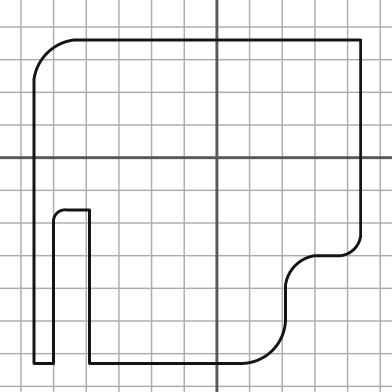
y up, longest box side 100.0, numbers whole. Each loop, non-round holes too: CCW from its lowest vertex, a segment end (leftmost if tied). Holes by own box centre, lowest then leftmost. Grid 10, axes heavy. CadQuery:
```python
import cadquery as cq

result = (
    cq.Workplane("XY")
    .moveTo(-56.0, -63.0)
    .lineTo(-50.0, -63.0)
    .lineTo(-50.0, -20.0)
    .threePointArc((-49.0, -17.0), (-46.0, -16.0))
    .lineTo(-39.0, -16.0)
    .lineTo(-39.0, -63.0)
    .lineTo(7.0, -63.0)
    .threePointArc((17.0, -59.0), (21.0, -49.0))
    .lineTo(21.0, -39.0)
    .threePointArc((24.0, -33.0), (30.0, -30.0))
    .lineTo(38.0, -30.0)
    .threePointArc((42.0, -28.0), (44.0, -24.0))
    .lineTo(44.0, 36.0)
    .lineTo(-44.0, 36.0)
    .threePointArc((-52.0, 32.0), (-56.0, 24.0))
    .close()
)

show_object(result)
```